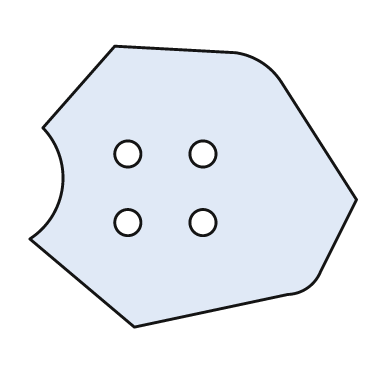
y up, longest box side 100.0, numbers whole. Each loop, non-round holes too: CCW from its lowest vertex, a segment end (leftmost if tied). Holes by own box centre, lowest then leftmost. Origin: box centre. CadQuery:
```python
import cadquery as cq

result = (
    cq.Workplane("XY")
    .moveTo(-18.0, -43.0)
    .lineTo(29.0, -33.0)
    .threePointArc((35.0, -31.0), (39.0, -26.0))
    .lineTo(50.0, -4.0)
    .lineTo(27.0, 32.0)
    .threePointArc((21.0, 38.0), (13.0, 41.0))
    .lineTo(-24.0, 43.0)
    .lineTo(-46.0, 18.0)
    .threePointArc((-40.0, 0.0), (-50.0, -16.0))
    .close()
    .moveTo(-20.0, -11.0)
    .circle(4.0)
    .moveTo(3.0, -11.0)
    .circle(4.0)
    .moveTo(-20.0, 10.0)
    .circle(4.0)
    .moveTo(3.0, 10.0)
    .circle(4.0)
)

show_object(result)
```